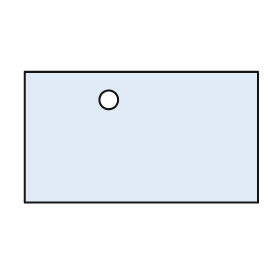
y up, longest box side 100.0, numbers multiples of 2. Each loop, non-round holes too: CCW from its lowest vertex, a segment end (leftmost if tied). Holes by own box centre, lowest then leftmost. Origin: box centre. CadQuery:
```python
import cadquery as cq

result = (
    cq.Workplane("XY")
    .moveTo(-50.0, -28.0)
    .lineTo(50.0, -28.0)
    .lineTo(50.0, 28.0)
    .lineTo(-50.0, 28.0)
    .close()
    .moveTo(-14.0, 16.0)
    .circle(4.0)
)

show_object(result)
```